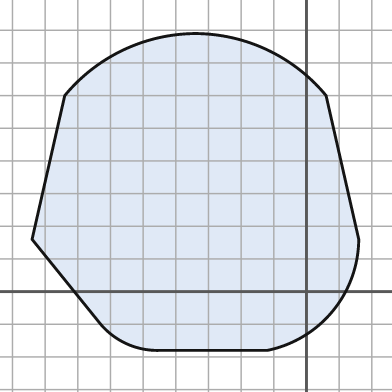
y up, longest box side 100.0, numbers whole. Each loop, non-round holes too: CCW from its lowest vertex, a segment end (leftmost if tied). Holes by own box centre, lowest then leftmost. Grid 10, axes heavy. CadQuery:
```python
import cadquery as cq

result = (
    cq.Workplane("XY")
    .moveTo(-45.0, -18.0)
    .lineTo(-12.0, -18.0)
    .threePointArc((8.0, -6.0), (16.0, 16.0))
    .lineTo(6.0, 60.0)
    .threePointArc((-12.0, 74.0), (-34.0, 79.0))
    .threePointArc((-56.0, 74.0), (-74.0, 60.0))
    .lineTo(-84.0, 16.0)
    .lineTo(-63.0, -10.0)
    .threePointArc((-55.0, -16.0), (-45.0, -18.0))
    .close()
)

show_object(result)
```